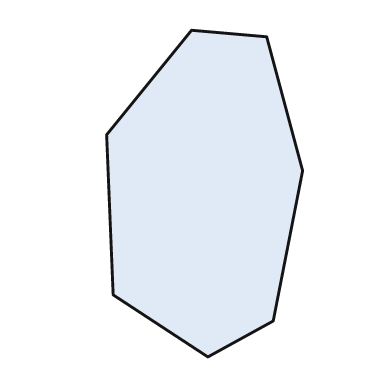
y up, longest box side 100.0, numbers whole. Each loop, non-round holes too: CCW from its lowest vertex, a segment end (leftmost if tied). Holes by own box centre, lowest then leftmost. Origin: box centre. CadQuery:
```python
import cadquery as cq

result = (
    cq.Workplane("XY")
    .moveTo(1.0, -50.0)
    .lineTo(21.0, -39.0)
    .lineTo(30.0, 7.0)
    .lineTo(19.0, 48.0)
    .lineTo(-4.0, 50.0)
    .lineTo(-30.0, 18.0)
    .lineTo(-28.0, -31.0)
    .close()
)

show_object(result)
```